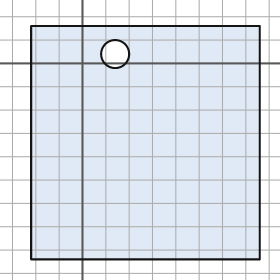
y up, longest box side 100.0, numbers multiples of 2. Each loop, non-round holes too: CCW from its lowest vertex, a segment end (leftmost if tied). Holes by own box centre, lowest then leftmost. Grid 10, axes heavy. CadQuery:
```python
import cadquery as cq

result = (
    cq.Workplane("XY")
    .moveTo(-22.0, -84.0)
    .lineTo(76.0, -84.0)
    .lineTo(76.0, 16.0)
    .lineTo(-22.0, 16.0)
    .close()
    .moveTo(14.0, 4.0)
    .circle(6.0)
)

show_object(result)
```